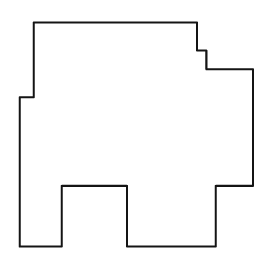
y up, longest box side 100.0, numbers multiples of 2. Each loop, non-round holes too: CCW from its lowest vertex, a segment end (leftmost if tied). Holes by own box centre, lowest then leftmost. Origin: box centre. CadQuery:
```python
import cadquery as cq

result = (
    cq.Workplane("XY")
    .moveTo(-50.0, -48.0)
    .lineTo(-32.0, -48.0)
    .lineTo(-32.0, -22.0)
    .lineTo(-4.0, -22.0)
    .lineTo(-4.0, -48.0)
    .lineTo(34.0, -48.0)
    .lineTo(34.0, -22.0)
    .lineTo(50.0, -22.0)
    .lineTo(50.0, 28.0)
    .lineTo(30.0, 28.0)
    .lineTo(30.0, 36.0)
    .lineTo(26.0, 36.0)
    .lineTo(26.0, 48.0)
    .lineTo(-44.0, 48.0)
    .lineTo(-44.0, 16.0)
    .lineTo(-50.0, 16.0)
    .close()
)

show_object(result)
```